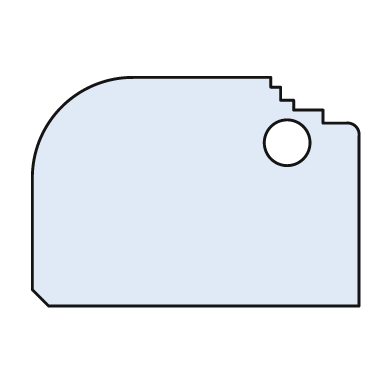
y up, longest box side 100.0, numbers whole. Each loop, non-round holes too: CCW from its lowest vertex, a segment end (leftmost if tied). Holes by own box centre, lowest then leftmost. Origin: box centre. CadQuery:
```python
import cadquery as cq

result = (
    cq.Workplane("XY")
    .moveTo(-45.0, -35.0)
    .lineTo(50.0, -35.0)
    .lineTo(50.0, 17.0)
    .threePointArc((49.0, 20.0), (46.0, 21.0))
    .lineTo(39.0, 21.0)
    .lineTo(39.0, 25.0)
    .lineTo(30.0, 25.0)
    .lineTo(30.0, 28.0)
    .lineTo(26.0, 28.0)
    .lineTo(26.0, 32.0)
    .lineTo(23.0, 32.0)
    .lineTo(23.0, 35.0)
    .lineTo(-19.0, 35.0)
    .threePointArc((-41.0, 26.0), (-50.0, 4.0))
    .lineTo(-50.0, -30.0)
    .close()
    .moveTo(28.0, 15.0)
    .circle(7.0)
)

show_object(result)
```